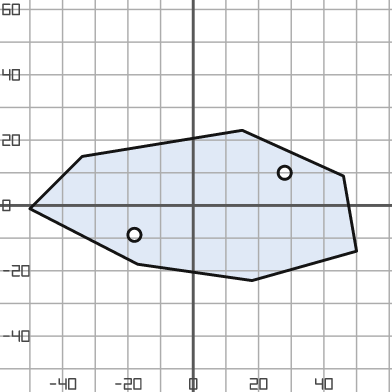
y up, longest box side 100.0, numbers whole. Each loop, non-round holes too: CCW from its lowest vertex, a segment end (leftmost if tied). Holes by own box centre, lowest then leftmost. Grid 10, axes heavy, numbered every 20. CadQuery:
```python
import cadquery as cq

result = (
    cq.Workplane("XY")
    .moveTo(18.0, -23.0)
    .lineTo(50.0, -14.0)
    .lineTo(46.0, 9.0)
    .lineTo(15.0, 23.0)
    .lineTo(-34.0, 15.0)
    .lineTo(-50.0, -1.0)
    .lineTo(-17.0, -18.0)
    .close()
    .moveTo(-18.0, -9.0)
    .circle(2.0)
    .moveTo(28.0, 10.0)
    .circle(2.0)
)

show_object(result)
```